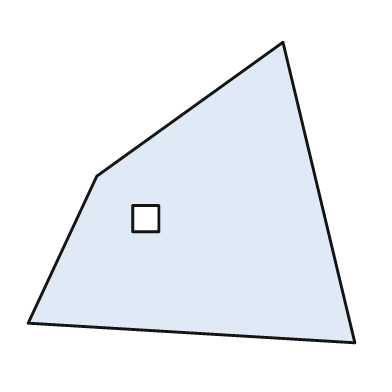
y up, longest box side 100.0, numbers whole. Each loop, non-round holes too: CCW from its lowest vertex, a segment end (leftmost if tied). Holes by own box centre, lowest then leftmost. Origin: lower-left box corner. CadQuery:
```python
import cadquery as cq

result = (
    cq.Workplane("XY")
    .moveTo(100.0, 0.0)
    .lineTo(78.0, 92.0)
    .lineTo(21.0, 51.0)
    .lineTo(0.0, 6.0)
    .close()
    .moveTo(32.0, 34.0)
    .lineTo(40.0, 34.0)
    .lineTo(40.0, 42.0)
    .lineTo(32.0, 42.0)
    .close()
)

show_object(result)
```